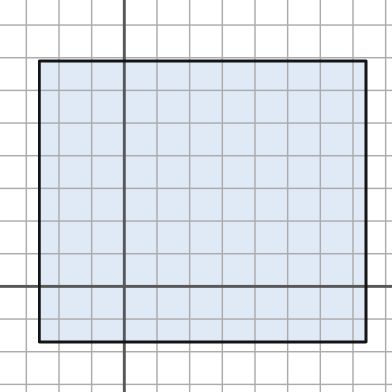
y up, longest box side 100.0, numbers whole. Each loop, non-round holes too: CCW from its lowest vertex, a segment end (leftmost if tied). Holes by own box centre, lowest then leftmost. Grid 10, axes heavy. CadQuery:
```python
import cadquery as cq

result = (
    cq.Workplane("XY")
    .moveTo(-26.0, -17.0)
    .lineTo(74.0, -17.0)
    .lineTo(74.0, 69.0)
    .lineTo(-26.0, 69.0)
    .close()
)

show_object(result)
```